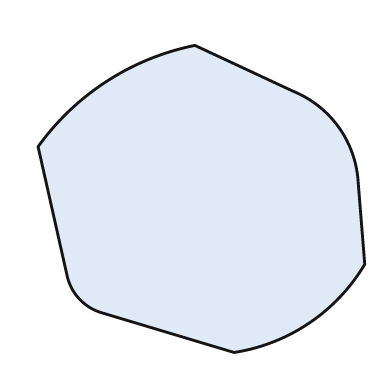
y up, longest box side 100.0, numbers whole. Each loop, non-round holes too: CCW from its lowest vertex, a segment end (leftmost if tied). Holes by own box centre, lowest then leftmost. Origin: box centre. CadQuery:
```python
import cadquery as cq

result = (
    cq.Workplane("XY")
    .moveTo(10.0, -47.0)
    .threePointArc((33.0, -38.0), (50.0, -20.0))
    .lineTo(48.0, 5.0)
    .threePointArc((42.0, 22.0), (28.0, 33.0))
    .lineTo(-2.0, 47.0)
    .threePointArc((-29.0, 36.0), (-50.0, 16.0))
    .lineTo(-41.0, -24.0)
    .threePointArc((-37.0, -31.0), (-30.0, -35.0))
    .close()
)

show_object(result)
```